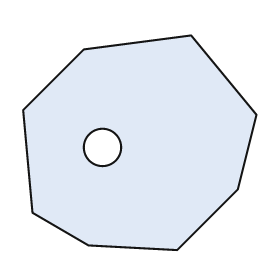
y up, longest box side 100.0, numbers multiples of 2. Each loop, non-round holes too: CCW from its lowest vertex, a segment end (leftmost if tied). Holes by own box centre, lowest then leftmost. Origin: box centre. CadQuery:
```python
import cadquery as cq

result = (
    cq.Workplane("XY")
    .moveTo(16.0, -46.0)
    .lineTo(42.0, -20.0)
    .lineTo(50.0, 12.0)
    .lineTo(22.0, 46.0)
    .lineTo(-24.0, 40.0)
    .lineTo(-50.0, 14.0)
    .lineTo(-46.0, -30.0)
    .lineTo(-22.0, -44.0)
    .close()
    .moveTo(-16.0, -2.0)
    .circle(8.0)
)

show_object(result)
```